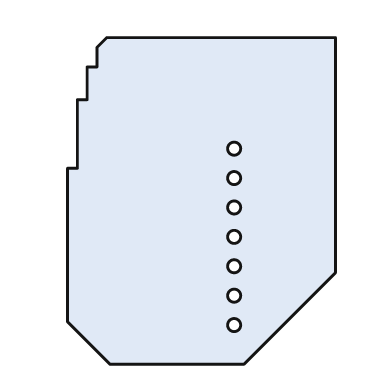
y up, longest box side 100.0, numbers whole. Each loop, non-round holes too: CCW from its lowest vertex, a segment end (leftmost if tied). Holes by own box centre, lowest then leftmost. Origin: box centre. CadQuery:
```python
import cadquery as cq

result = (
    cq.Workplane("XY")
    .moveTo(-28.0, -50.0)
    .lineTo(13.0, -50.0)
    .lineTo(41.0, -22.0)
    .lineTo(41.0, 50.0)
    .lineTo(-29.0, 50.0)
    .lineTo(-32.0, 47.0)
    .lineTo(-32.0, 41.0)
    .lineTo(-35.0, 41.0)
    .lineTo(-35.0, 31.0)
    .lineTo(-38.0, 31.0)
    .lineTo(-38.0, 10.0)
    .lineTo(-41.0, 10.0)
    .lineTo(-41.0, -37.0)
    .close()
    .moveTo(10.0, -38.0)
    .circle(2.0)
    .moveTo(10.0, -29.0)
    .circle(2.0)
    .moveTo(10.0, -20.0)
    .circle(2.0)
    .moveTo(10.0, -11.0)
    .circle(2.0)
    .moveTo(10.0, -2.0)
    .circle(2.0)
    .moveTo(10.0, 7.0)
    .circle(2.0)
    .moveTo(10.0, 16.0)
    .circle(2.0)
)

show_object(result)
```